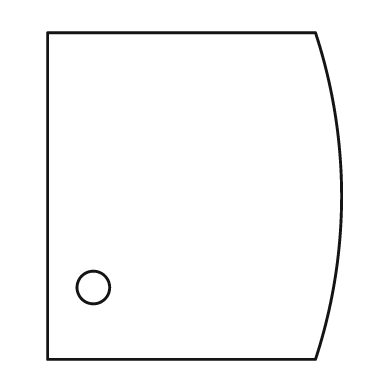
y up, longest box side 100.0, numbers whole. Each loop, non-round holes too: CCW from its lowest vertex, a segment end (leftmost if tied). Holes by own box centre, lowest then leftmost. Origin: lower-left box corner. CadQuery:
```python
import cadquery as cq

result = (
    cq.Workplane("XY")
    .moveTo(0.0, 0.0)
    .lineTo(82.0, 0.0)
    .threePointArc((90.0, 50.0), (82.0, 100.0))
    .lineTo(0.0, 100.0)
    .close()
    .moveTo(14.0, 22.0)
    .circle(5.0)
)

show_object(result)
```